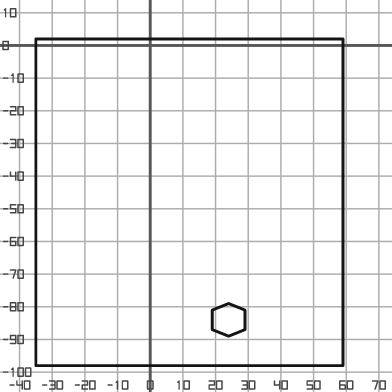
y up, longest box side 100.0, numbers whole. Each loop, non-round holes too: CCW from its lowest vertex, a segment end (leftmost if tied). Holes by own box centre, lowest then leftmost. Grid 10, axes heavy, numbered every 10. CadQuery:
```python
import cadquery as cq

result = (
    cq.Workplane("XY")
    .moveTo(-35.0, -98.0)
    .lineTo(59.0, -98.0)
    .lineTo(59.0, 2.0)
    .lineTo(-35.0, 2.0)
    .close()
    .moveTo(24.0, -89.0)
    .lineTo(29.0, -87.0)
    .lineTo(29.0, -81.0)
    .lineTo(24.0, -79.0)
    .lineTo(19.0, -81.0)
    .lineTo(19.0, -87.0)
    .close()
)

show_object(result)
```